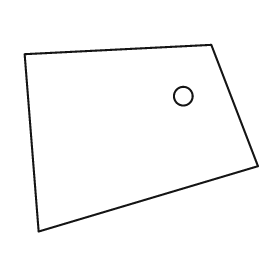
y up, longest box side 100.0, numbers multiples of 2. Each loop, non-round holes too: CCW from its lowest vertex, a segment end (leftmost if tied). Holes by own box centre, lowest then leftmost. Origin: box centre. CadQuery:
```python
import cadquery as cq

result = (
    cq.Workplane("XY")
    .moveTo(-44.0, -40.0)
    .lineTo(50.0, -12.0)
    .lineTo(30.0, 40.0)
    .lineTo(-50.0, 36.0)
    .close()
    .moveTo(18.0, 18.0)
    .circle(4.0)
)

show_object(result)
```